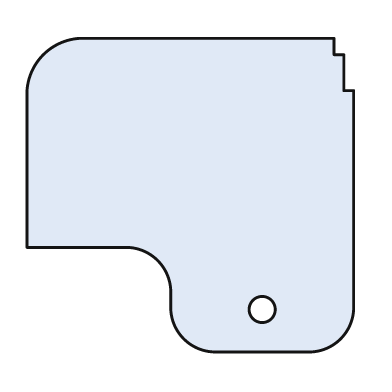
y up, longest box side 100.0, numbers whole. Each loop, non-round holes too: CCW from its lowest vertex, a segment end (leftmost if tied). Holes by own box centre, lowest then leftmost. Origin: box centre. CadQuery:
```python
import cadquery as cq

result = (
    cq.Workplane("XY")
    .moveTo(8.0, -48.0)
    .lineTo(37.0, -48.0)
    .threePointArc((46.0, -44.0), (50.0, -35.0))
    .lineTo(50.0, 32.0)
    .lineTo(47.0, 32.0)
    .lineTo(47.0, 43.0)
    .lineTo(44.0, 43.0)
    .lineTo(44.0, 48.0)
    .lineTo(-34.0, 48.0)
    .threePointArc((-45.0, 43.0), (-50.0, 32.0))
    .lineTo(-50.0, -16.0)
    .lineTo(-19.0, -16.0)
    .threePointArc((-10.0, -20.0), (-6.0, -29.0))
    .lineTo(-6.0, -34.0)
    .threePointArc((-2.0, -44.0), (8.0, -48.0))
    .close()
    .moveTo(22.0, -35.0)
    .circle(4.0)
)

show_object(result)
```